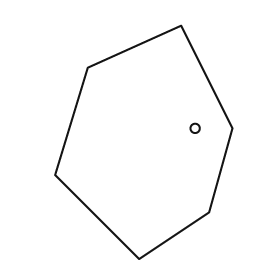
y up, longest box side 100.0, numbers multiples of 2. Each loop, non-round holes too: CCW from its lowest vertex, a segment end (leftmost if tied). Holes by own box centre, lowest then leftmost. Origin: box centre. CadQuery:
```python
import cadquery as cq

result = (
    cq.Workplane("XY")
    .moveTo(-2.0, -50.0)
    .lineTo(28.0, -30.0)
    .lineTo(38.0, 6.0)
    .lineTo(16.0, 50.0)
    .lineTo(-24.0, 32.0)
    .lineTo(-38.0, -14.0)
    .close()
    .moveTo(22.0, 6.0)
    .circle(2.0)
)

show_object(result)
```